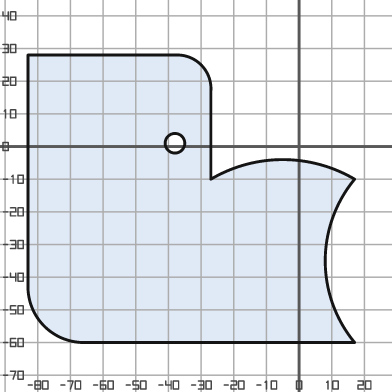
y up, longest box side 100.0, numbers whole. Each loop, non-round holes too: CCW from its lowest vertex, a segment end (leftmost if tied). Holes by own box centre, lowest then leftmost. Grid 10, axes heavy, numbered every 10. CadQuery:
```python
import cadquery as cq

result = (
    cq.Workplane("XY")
    .moveTo(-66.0, -60.0)
    .lineTo(17.0, -60.0)
    .threePointArc((8.0, -35.0), (17.0, -10.0))
    .threePointArc((-5.0, -4.0), (-27.0, -10.0))
    .lineTo(-27.0, 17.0)
    .threePointArc((-30.0, 25.0), (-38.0, 28.0))
    .lineTo(-83.0, 28.0)
    .lineTo(-83.0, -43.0)
    .threePointArc((-78.0, -55.0), (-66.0, -60.0))
    .close()
    .moveTo(-38.0, 1.0)
    .circle(3.0)
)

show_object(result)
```